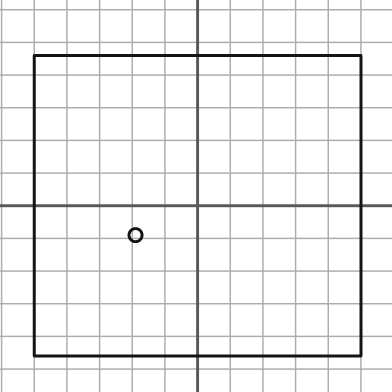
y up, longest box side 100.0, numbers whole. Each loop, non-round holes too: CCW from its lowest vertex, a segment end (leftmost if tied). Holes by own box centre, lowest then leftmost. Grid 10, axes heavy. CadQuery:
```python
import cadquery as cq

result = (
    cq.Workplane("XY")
    .moveTo(-50.0, -46.0)
    .lineTo(50.0, -46.0)
    .lineTo(50.0, 46.0)
    .lineTo(-50.0, 46.0)
    .close()
    .moveTo(-19.0, -9.0)
    .circle(2.0)
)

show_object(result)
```